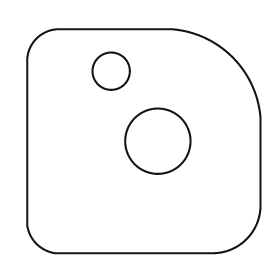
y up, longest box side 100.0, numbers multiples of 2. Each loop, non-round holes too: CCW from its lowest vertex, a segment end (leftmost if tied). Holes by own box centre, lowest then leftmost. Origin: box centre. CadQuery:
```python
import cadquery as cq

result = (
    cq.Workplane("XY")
    .moveTo(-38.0, -48.0)
    .lineTo(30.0, -48.0)
    .threePointArc((44.0, -42.0), (50.0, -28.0))
    .lineTo(50.0, 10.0)
    .threePointArc((38.0, 36.0), (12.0, 48.0))
    .lineTo(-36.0, 48.0)
    .threePointArc((-46.0, 44.0), (-50.0, 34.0))
    .lineTo(-50.0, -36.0)
    .threePointArc((-46.0, -44.0), (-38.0, -48.0))
    .close()
    .moveTo(6.0, 0.0)
    .circle(14.0)
    .moveTo(-14.0, 30.0)
    .circle(8.0)
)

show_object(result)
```